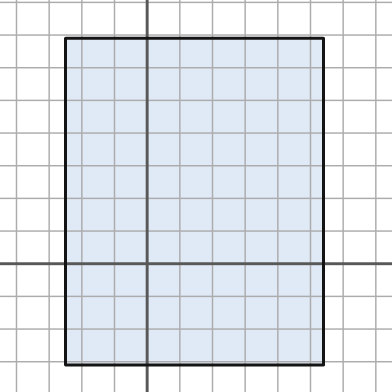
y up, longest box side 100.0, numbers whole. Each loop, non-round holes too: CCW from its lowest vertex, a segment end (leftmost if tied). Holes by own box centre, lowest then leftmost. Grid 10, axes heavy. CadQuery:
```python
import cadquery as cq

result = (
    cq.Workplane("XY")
    .moveTo(-25.0, -31.0)
    .lineTo(54.0, -31.0)
    .lineTo(54.0, 69.0)
    .lineTo(-25.0, 69.0)
    .close()
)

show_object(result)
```